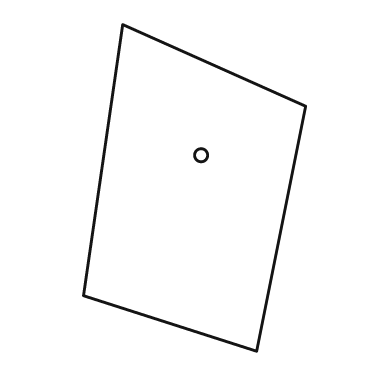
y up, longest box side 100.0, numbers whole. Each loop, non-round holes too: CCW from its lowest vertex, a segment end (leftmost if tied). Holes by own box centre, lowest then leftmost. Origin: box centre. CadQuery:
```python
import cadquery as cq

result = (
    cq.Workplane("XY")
    .moveTo(19.0, -50.0)
    .lineTo(34.0, 25.0)
    .lineTo(-22.0, 50.0)
    .lineTo(-34.0, -33.0)
    .close()
    .moveTo(2.0, 10.0)
    .circle(2.0)
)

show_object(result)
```